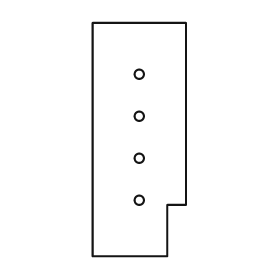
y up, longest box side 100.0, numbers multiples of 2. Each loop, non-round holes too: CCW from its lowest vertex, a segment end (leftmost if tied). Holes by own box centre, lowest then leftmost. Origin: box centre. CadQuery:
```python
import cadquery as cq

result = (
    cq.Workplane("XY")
    .moveTo(-20.0, -50.0)
    .lineTo(12.0, -50.0)
    .lineTo(12.0, -28.0)
    .lineTo(20.0, -28.0)
    .lineTo(20.0, 50.0)
    .lineTo(-20.0, 50.0)
    .close()
    .moveTo(0.0, -26.0)
    .circle(2.0)
    .moveTo(0.0, -8.0)
    .circle(2.0)
    .moveTo(0.0, 10.0)
    .circle(2.0)
    .moveTo(0.0, 28.0)
    .circle(2.0)
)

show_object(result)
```